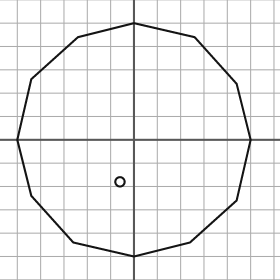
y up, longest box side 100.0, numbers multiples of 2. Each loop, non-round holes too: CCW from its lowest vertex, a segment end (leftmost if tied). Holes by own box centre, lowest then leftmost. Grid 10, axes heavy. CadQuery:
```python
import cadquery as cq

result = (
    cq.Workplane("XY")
    .moveTo(0.0, -50.0)
    .lineTo(24.0, -44.0)
    .lineTo(44.0, -26.0)
    .lineTo(50.0, 0.0)
    .lineTo(44.0, 24.0)
    .lineTo(26.0, 44.0)
    .lineTo(0.0, 50.0)
    .lineTo(-24.0, 44.0)
    .lineTo(-44.0, 26.0)
    .lineTo(-50.0, 0.0)
    .lineTo(-44.0, -24.0)
    .lineTo(-26.0, -44.0)
    .close()
    .moveTo(-6.0, -18.0)
    .circle(2.0)
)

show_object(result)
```